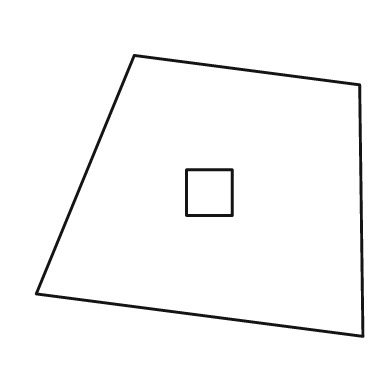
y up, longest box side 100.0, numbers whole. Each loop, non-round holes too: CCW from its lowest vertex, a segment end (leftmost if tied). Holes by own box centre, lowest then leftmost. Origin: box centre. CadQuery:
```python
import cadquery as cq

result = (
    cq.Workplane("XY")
    .moveTo(50.0, -43.0)
    .lineTo(49.0, 34.0)
    .lineTo(-20.0, 43.0)
    .lineTo(-50.0, -30.0)
    .close()
    .moveTo(-4.0, -6.0)
    .lineTo(10.0, -6.0)
    .lineTo(10.0, 8.0)
    .lineTo(-4.0, 8.0)
    .close()
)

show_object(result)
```